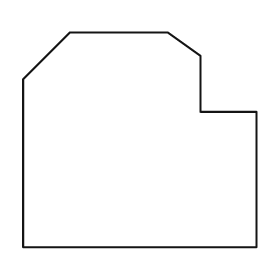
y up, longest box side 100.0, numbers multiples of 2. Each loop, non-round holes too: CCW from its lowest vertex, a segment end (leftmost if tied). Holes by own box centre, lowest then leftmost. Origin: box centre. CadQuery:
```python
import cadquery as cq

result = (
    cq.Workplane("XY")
    .moveTo(-50.0, -46.0)
    .lineTo(50.0, -46.0)
    .lineTo(50.0, 12.0)
    .lineTo(26.0, 12.0)
    .lineTo(26.0, 36.0)
    .lineTo(12.0, 46.0)
    .lineTo(-30.0, 46.0)
    .lineTo(-50.0, 26.0)
    .close()
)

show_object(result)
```